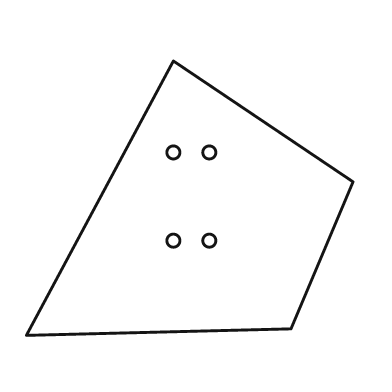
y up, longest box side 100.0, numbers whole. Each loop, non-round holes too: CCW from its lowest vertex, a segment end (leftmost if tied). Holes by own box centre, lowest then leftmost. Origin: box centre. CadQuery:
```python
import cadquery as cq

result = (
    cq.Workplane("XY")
    .moveTo(-50.0, -42.0)
    .lineTo(31.0, -40.0)
    .lineTo(50.0, 5.0)
    .lineTo(-5.0, 42.0)
    .close()
    .moveTo(-5.0, -13.0)
    .circle(2.0)
    .moveTo(6.0, -13.0)
    .circle(2.0)
    .moveTo(-5.0, 14.0)
    .circle(2.0)
    .moveTo(6.0, 14.0)
    .circle(2.0)
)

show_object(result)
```